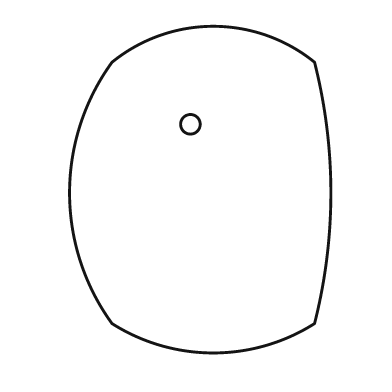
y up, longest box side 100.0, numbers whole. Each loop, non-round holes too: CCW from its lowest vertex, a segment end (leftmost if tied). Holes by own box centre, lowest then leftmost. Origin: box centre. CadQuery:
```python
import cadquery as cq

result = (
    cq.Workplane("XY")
    .moveTo(-27.0, -41.0)
    .threePointArc((4.0, -50.0), (35.0, -41.0))
    .threePointArc((40.0, -1.0), (35.0, 39.0))
    .threePointArc((4.0, 50.0), (-27.0, 39.0))
    .threePointArc((-40.0, -1.0), (-27.0, -41.0))
    .close()
    .moveTo(-3.0, 20.0)
    .circle(3.0)
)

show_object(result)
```